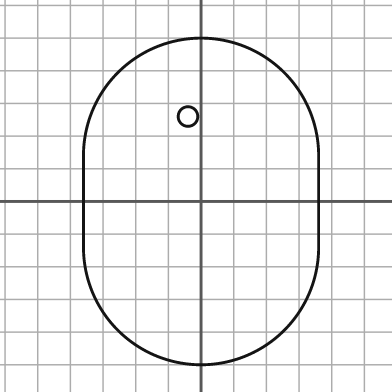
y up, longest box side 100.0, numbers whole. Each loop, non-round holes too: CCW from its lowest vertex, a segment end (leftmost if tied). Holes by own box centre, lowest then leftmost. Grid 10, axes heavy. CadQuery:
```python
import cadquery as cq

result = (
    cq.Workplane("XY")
    .moveTo(-36.0, -14.0)
    .threePointArc((0.0, -50.0), (36.0, -14.0))
    .lineTo(36.0, 14.0)
    .threePointArc((0.0, 50.0), (-36.0, 14.0))
    .close()
    .moveTo(-4.0, 26.0)
    .circle(3.0)
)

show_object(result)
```